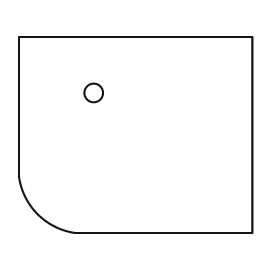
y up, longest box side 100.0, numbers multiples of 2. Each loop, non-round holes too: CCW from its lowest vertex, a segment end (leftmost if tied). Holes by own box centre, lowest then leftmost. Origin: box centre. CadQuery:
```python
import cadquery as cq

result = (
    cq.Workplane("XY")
    .moveTo(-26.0, -42.0)
    .lineTo(50.0, -42.0)
    .lineTo(50.0, 42.0)
    .lineTo(-50.0, 42.0)
    .lineTo(-50.0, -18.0)
    .threePointArc((-42.0, -34.0), (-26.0, -42.0))
    .close()
    .moveTo(-18.0, 18.0)
    .circle(4.0)
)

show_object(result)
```